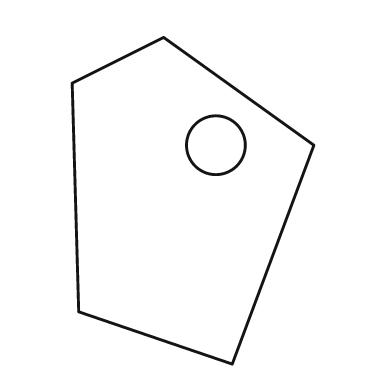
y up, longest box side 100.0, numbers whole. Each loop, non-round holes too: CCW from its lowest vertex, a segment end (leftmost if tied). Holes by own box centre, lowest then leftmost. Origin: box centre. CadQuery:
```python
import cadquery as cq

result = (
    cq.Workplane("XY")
    .moveTo(12.0, -50.0)
    .lineTo(37.0, 17.0)
    .lineTo(-9.0, 50.0)
    .lineTo(-37.0, 36.0)
    .lineTo(-35.0, -34.0)
    .close()
    .moveTo(7.0, 17.0)
    .circle(9.0)
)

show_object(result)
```